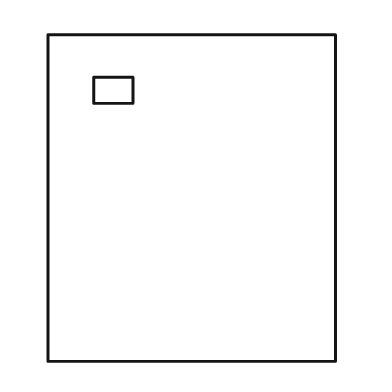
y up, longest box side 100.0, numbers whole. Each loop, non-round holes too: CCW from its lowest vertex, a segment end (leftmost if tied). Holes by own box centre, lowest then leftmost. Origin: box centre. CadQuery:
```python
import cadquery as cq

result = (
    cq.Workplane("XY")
    .moveTo(-44.0, -50.0)
    .lineTo(44.0, -50.0)
    .lineTo(44.0, 50.0)
    .lineTo(-44.0, 50.0)
    .close()
    .moveTo(-30.0, 29.0)
    .lineTo(-18.0, 29.0)
    .lineTo(-18.0, 37.0)
    .lineTo(-30.0, 37.0)
    .close()
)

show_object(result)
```